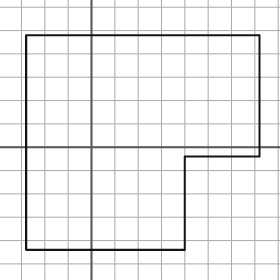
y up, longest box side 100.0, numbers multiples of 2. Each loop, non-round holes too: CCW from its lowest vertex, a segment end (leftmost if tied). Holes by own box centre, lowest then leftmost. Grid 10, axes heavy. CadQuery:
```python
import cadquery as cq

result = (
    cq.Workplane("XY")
    .moveTo(-28.0, -44.0)
    .lineTo(40.0, -44.0)
    .lineTo(40.0, -4.0)
    .lineTo(72.0, -4.0)
    .lineTo(72.0, 48.0)
    .lineTo(-28.0, 48.0)
    .close()
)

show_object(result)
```